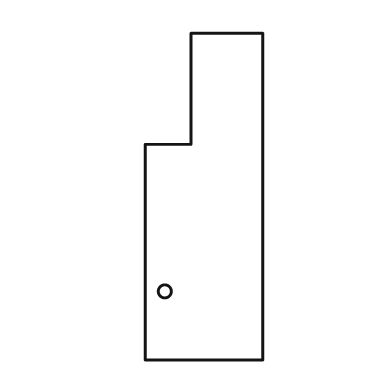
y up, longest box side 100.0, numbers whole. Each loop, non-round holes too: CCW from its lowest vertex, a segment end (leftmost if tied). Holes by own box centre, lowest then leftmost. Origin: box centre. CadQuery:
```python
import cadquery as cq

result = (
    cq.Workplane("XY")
    .moveTo(-18.0, -50.0)
    .lineTo(18.0, -50.0)
    .lineTo(18.0, 50.0)
    .lineTo(-4.0, 50.0)
    .lineTo(-4.0, 16.0)
    .lineTo(-18.0, 16.0)
    .close()
    .moveTo(-12.0, -29.0)
    .circle(2.0)
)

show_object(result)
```